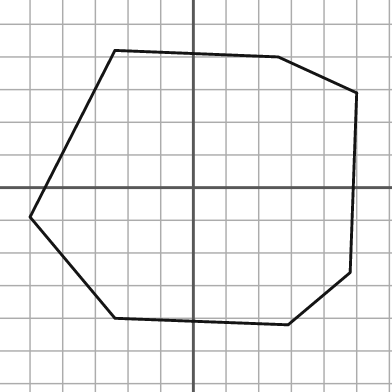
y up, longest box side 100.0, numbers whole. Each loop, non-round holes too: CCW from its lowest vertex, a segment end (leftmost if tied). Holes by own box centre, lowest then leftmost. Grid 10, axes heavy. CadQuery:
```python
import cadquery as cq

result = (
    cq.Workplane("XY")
    .moveTo(29.0, -42.0)
    .lineTo(48.0, -26.0)
    .lineTo(50.0, 29.0)
    .lineTo(26.0, 40.0)
    .lineTo(-24.0, 42.0)
    .lineTo(-50.0, -9.0)
    .lineTo(-24.0, -40.0)
    .close()
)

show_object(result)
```